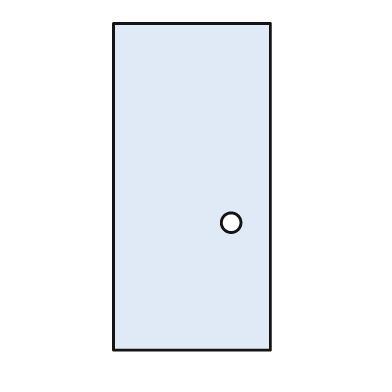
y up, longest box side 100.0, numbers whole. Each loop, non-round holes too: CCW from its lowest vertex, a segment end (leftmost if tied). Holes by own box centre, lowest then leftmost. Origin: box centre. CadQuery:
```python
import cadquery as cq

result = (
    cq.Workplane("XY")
    .moveTo(-24.0, -50.0)
    .lineTo(24.0, -50.0)
    .lineTo(24.0, 50.0)
    .lineTo(-24.0, 50.0)
    .close()
    .moveTo(12.0, -11.0)
    .circle(3.0)
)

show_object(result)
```